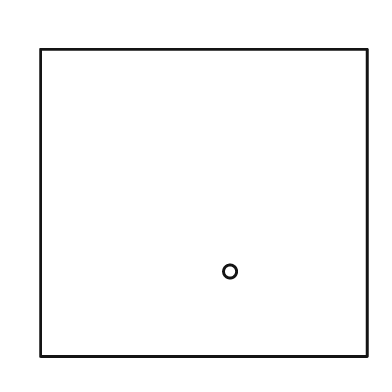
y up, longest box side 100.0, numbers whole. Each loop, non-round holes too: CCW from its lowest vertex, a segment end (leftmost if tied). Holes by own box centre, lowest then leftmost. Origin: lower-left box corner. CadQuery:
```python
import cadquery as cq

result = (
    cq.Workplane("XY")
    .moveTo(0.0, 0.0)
    .lineTo(100.0, 0.0)
    .lineTo(100.0, 94.0)
    .lineTo(0.0, 94.0)
    .close()
    .moveTo(58.0, 26.0)
    .circle(2.0)
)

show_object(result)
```